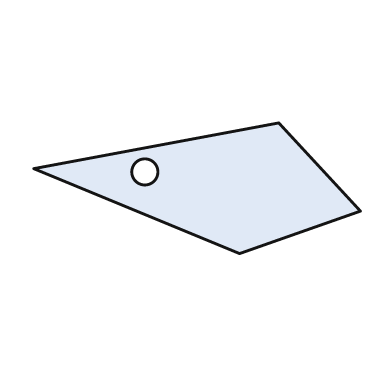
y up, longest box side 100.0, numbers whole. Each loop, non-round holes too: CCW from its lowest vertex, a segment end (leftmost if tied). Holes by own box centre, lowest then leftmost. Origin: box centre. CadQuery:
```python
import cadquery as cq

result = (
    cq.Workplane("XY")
    .moveTo(13.0, -20.0)
    .lineTo(50.0, -7.0)
    .lineTo(25.0, 20.0)
    .lineTo(-50.0, 6.0)
    .close()
    .moveTo(-16.0, 5.0)
    .circle(4.0)
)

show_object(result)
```